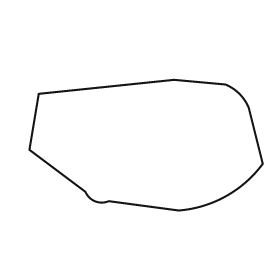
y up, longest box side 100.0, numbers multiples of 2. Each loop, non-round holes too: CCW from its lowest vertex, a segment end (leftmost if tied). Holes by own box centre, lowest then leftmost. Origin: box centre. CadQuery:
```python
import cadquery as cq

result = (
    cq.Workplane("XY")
    .moveTo(14.0, -28.0)
    .threePointArc((34.0, -22.0), (50.0, -8.0))
    .lineTo(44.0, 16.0)
    .threePointArc((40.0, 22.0), (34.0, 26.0))
    .lineTo(12.0, 28.0)
    .lineTo(-46.0, 22.0)
    .lineTo(-50.0, -2.0)
    .lineTo(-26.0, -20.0)
    .threePointArc((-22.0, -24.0), (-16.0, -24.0))
    .close()
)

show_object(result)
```